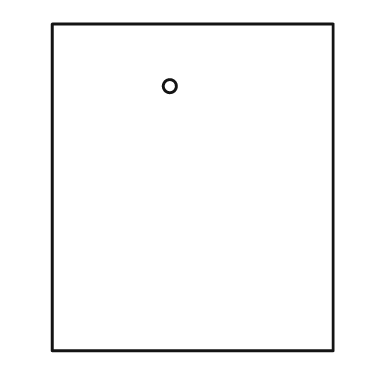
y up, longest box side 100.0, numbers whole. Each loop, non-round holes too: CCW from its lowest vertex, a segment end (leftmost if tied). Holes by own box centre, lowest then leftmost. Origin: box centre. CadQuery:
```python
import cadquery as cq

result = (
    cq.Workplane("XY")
    .moveTo(-43.0, -50.0)
    .lineTo(43.0, -50.0)
    .lineTo(43.0, 50.0)
    .lineTo(-43.0, 50.0)
    .close()
    .moveTo(-7.0, 31.0)
    .circle(2.0)
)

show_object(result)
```